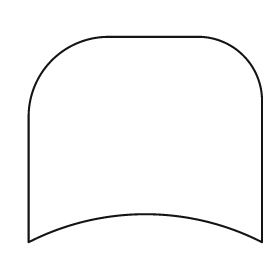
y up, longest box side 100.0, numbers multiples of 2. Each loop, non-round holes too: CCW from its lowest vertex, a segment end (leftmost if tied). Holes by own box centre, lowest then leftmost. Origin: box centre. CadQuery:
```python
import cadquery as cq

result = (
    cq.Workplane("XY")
    .moveTo(-50.0, -44.0)
    .threePointArc((0.0, -32.0), (50.0, -44.0))
    .lineTo(50.0, 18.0)
    .threePointArc((42.0, 36.0), (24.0, 44.0))
    .lineTo(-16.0, 44.0)
    .threePointArc((-40.0, 34.0), (-50.0, 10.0))
    .close()
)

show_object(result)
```